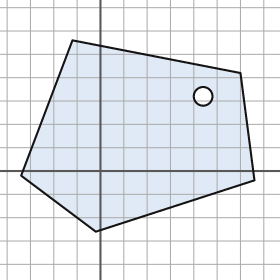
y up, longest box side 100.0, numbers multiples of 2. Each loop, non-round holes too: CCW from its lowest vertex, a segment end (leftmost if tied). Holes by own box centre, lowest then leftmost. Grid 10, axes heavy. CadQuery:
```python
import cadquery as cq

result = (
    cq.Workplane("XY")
    .moveTo(-2.0, -26.0)
    .lineTo(66.0, -4.0)
    .lineTo(60.0, 42.0)
    .lineTo(-12.0, 56.0)
    .lineTo(-34.0, -2.0)
    .close()
    .moveTo(44.0, 32.0)
    .circle(4.0)
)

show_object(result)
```